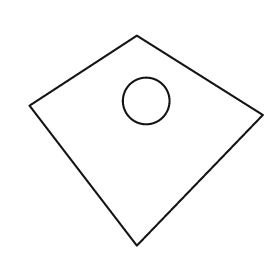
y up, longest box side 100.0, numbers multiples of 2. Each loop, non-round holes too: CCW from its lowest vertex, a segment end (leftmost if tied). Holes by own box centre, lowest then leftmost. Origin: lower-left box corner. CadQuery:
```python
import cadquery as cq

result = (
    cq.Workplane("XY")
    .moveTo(46.0, 0.0)
    .lineTo(100.0, 56.0)
    .lineTo(46.0, 90.0)
    .lineTo(0.0, 60.0)
    .close()
    .moveTo(50.0, 62.0)
    .circle(10.0)
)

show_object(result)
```